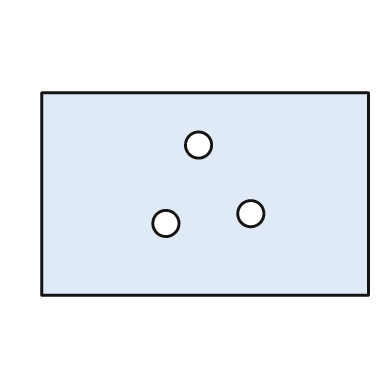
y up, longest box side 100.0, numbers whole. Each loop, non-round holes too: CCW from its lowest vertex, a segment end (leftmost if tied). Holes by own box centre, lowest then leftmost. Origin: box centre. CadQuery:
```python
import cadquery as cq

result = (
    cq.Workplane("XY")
    .moveTo(-50.0, -31.0)
    .lineTo(50.0, -31.0)
    .lineTo(50.0, 31.0)
    .lineTo(-50.0, 31.0)
    .close()
    .moveTo(-12.0, -9.0)
    .circle(4.0)
    .moveTo(14.0, -6.0)
    .circle(4.0)
    .moveTo(-2.0, 15.0)
    .circle(4.0)
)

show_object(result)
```